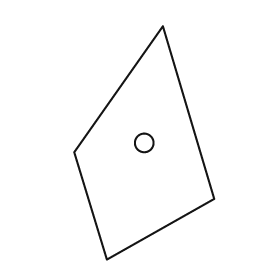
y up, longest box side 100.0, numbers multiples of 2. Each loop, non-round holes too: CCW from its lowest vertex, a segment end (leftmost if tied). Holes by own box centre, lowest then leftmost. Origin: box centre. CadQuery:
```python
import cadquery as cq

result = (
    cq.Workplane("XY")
    .moveTo(-16.0, -50.0)
    .lineTo(30.0, -24.0)
    .lineTo(8.0, 50.0)
    .lineTo(-30.0, -4.0)
    .close()
    .moveTo(0.0, 0.0)
    .circle(4.0)
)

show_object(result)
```